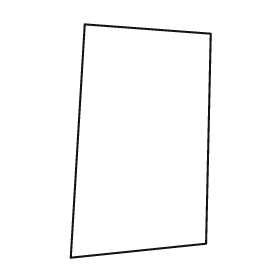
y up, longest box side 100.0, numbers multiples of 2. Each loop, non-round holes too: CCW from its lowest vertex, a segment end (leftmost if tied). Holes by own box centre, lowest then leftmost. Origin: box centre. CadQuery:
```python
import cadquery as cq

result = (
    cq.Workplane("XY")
    .moveTo(-30.0, -50.0)
    .lineTo(28.0, -44.0)
    .lineTo(30.0, 46.0)
    .lineTo(-24.0, 50.0)
    .close()
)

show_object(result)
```